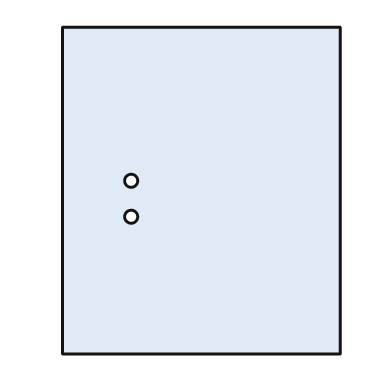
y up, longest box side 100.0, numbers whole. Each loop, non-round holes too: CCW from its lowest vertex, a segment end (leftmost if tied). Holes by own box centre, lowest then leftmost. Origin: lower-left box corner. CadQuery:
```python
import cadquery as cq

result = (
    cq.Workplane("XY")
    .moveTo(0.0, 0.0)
    .lineTo(85.0, 0.0)
    .lineTo(85.0, 100.0)
    .lineTo(0.0, 100.0)
    .close()
    .moveTo(21.0, 42.0)
    .circle(2.0)
    .moveTo(21.0, 53.0)
    .circle(2.0)
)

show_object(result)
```